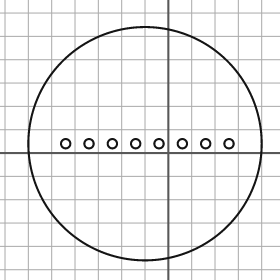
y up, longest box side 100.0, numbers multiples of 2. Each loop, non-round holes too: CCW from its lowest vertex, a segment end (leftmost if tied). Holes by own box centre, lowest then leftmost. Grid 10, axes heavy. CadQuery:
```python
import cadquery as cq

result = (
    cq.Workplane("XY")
    .moveTo(-10.0, 4.0)
    .circle(50.0)
    .moveTo(-44.0, 4.0)
    .circle(2.0)
    .moveTo(-34.0, 4.0)
    .circle(2.0)
    .moveTo(-24.0, 4.0)
    .circle(2.0)
    .moveTo(-14.0, 4.0)
    .circle(2.0)
    .moveTo(-4.0, 4.0)
    .circle(2.0)
    .moveTo(6.0, 4.0)
    .circle(2.0)
    .moveTo(16.0, 4.0)
    .circle(2.0)
    .moveTo(26.0, 4.0)
    .circle(2.0)
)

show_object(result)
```